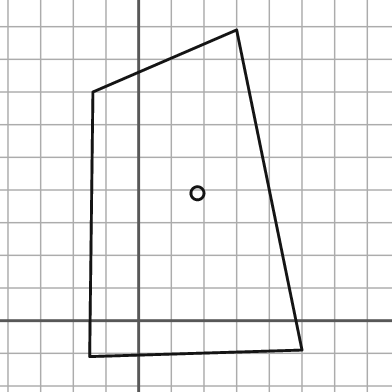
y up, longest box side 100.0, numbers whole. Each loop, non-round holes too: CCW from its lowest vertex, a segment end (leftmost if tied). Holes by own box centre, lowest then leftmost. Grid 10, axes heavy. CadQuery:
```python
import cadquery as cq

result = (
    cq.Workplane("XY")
    .moveTo(-15.0, -11.0)
    .lineTo(50.0, -9.0)
    .lineTo(30.0, 89.0)
    .lineTo(-14.0, 70.0)
    .close()
    .moveTo(18.0, 39.0)
    .circle(2.0)
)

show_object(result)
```